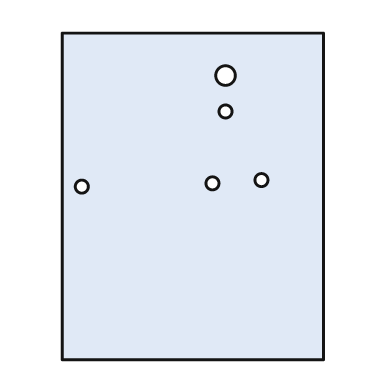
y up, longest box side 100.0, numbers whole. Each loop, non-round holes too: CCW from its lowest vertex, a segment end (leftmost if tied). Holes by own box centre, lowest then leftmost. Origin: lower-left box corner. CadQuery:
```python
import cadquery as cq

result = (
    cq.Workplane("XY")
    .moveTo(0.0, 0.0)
    .lineTo(80.0, 0.0)
    .lineTo(80.0, 100.0)
    .lineTo(0.0, 100.0)
    .close()
    .moveTo(6.0, 53.0)
    .circle(2.0)
    .moveTo(46.0, 54.0)
    .circle(2.0)
    .moveTo(61.0, 55.0)
    .circle(2.0)
    .moveTo(50.0, 76.0)
    .circle(2.0)
    .moveTo(50.0, 87.0)
    .circle(3.0)
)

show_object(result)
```